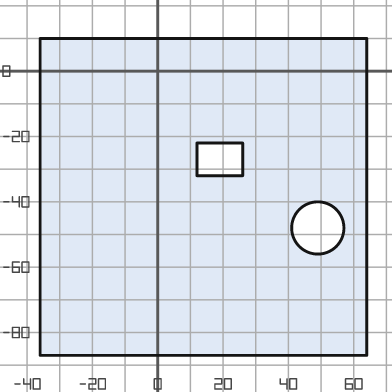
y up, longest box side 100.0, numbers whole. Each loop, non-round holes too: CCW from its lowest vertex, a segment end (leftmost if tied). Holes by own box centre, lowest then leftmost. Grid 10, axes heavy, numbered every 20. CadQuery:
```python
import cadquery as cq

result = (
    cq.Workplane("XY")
    .moveTo(-36.0, -87.0)
    .lineTo(64.0, -87.0)
    .lineTo(64.0, 10.0)
    .lineTo(-36.0, 10.0)
    .close()
    .moveTo(49.0, -48.0)
    .circle(8.0)
    .moveTo(12.0, -32.0)
    .lineTo(26.0, -32.0)
    .lineTo(26.0, -22.0)
    .lineTo(12.0, -22.0)
    .close()
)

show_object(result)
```